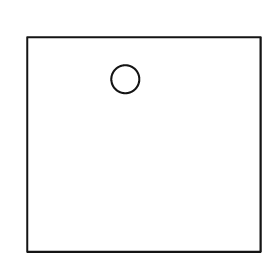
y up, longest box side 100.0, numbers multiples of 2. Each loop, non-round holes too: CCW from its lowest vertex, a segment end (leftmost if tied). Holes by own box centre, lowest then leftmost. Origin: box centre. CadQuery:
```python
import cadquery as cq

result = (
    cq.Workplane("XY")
    .moveTo(-50.0, -46.0)
    .lineTo(50.0, -46.0)
    .lineTo(50.0, 46.0)
    .lineTo(-50.0, 46.0)
    .close()
    .moveTo(-8.0, 28.0)
    .circle(6.0)
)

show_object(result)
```